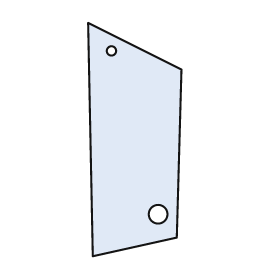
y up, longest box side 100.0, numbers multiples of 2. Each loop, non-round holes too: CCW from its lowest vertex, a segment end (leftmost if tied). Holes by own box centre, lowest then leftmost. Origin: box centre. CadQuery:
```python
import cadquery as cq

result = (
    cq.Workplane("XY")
    .moveTo(-18.0, -50.0)
    .lineTo(18.0, -42.0)
    .lineTo(20.0, 30.0)
    .lineTo(-20.0, 50.0)
    .close()
    .moveTo(10.0, -32.0)
    .circle(4.0)
    .moveTo(-10.0, 38.0)
    .circle(2.0)
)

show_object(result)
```